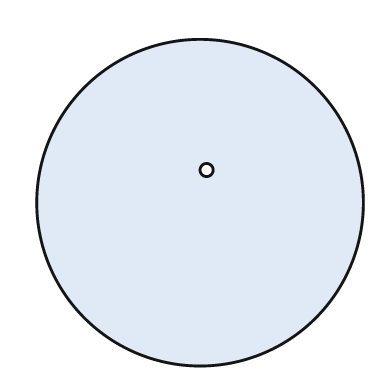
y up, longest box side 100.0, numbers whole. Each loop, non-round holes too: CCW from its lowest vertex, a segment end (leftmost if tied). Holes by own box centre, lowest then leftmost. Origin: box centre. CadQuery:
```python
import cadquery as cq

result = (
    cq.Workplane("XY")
    .moveTo(0.0, 0.0)
    .circle(50.0)
    .moveTo(2.0, 10.0)
    .circle(2.0)
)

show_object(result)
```